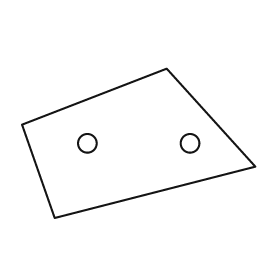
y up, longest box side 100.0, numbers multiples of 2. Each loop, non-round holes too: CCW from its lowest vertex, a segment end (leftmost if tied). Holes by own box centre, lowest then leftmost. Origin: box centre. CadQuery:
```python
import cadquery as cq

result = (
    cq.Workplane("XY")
    .moveTo(-36.0, -32.0)
    .lineTo(50.0, -10.0)
    .lineTo(12.0, 32.0)
    .lineTo(-50.0, 8.0)
    .close()
    .moveTo(-22.0, 0.0)
    .circle(4.0)
    .moveTo(22.0, 0.0)
    .circle(4.0)
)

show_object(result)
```